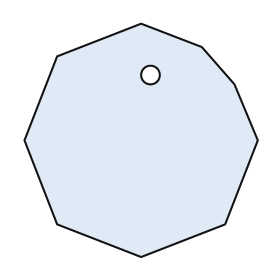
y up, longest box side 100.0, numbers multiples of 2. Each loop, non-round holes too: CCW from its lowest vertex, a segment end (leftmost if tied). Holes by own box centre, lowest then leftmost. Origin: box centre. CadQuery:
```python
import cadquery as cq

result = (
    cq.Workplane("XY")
    .moveTo(0.0, -50.0)
    .lineTo(36.0, -36.0)
    .lineTo(50.0, 0.0)
    .lineTo(40.0, 24.0)
    .lineTo(26.0, 40.0)
    .lineTo(0.0, 50.0)
    .lineTo(-36.0, 36.0)
    .lineTo(-50.0, 0.0)
    .lineTo(-36.0, -36.0)
    .close()
    .moveTo(4.0, 28.0)
    .circle(4.0)
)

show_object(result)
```